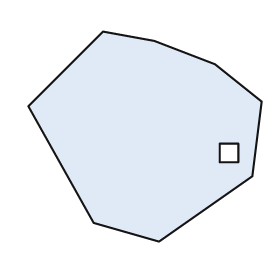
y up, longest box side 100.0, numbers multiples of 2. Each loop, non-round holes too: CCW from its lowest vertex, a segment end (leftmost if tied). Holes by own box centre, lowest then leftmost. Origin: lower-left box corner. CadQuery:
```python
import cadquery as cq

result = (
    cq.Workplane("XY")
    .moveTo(56.0, 0.0)
    .lineTo(96.0, 28.0)
    .lineTo(100.0, 60.0)
    .lineTo(80.0, 76.0)
    .lineTo(54.0, 86.0)
    .lineTo(32.0, 90.0)
    .lineTo(0.0, 58.0)
    .lineTo(28.0, 8.0)
    .close()
    .moveTo(82.0, 34.0)
    .lineTo(90.0, 34.0)
    .lineTo(90.0, 42.0)
    .lineTo(82.0, 42.0)
    .close()
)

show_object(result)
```